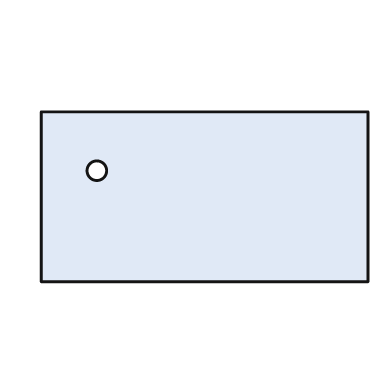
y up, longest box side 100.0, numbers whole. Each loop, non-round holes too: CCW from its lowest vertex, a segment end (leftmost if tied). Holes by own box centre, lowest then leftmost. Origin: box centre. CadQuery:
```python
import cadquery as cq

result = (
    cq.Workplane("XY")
    .moveTo(-50.0, -26.0)
    .lineTo(50.0, -26.0)
    .lineTo(50.0, 26.0)
    .lineTo(-50.0, 26.0)
    .close()
    .moveTo(-33.0, 8.0)
    .circle(3.0)
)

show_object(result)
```